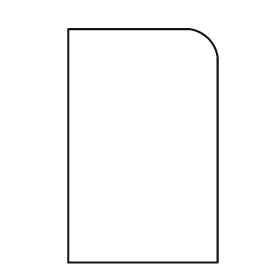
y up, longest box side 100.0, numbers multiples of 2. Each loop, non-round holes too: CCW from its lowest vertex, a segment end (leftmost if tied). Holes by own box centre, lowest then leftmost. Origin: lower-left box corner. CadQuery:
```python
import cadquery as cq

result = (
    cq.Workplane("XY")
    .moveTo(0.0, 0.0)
    .lineTo(64.0, 0.0)
    .lineTo(64.0, 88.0)
    .threePointArc((60.0, 96.0), (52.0, 100.0))
    .lineTo(0.0, 100.0)
    .close()
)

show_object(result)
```